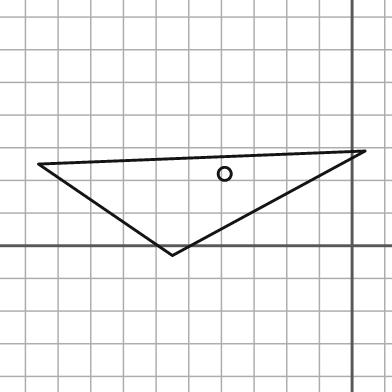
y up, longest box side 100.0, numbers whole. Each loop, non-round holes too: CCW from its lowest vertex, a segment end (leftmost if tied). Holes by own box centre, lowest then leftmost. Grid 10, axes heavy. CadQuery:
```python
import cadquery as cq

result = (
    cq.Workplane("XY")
    .moveTo(-55.0, -3.0)
    .lineTo(4.0, 29.0)
    .lineTo(-96.0, 25.0)
    .close()
    .moveTo(-39.0, 22.0)
    .circle(2.0)
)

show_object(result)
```